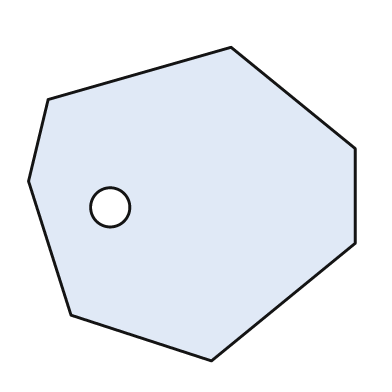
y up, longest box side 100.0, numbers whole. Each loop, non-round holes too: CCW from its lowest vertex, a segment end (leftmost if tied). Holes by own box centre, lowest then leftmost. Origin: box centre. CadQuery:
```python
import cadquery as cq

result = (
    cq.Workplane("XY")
    .moveTo(6.0, -48.0)
    .lineTo(50.0, -12.0)
    .lineTo(50.0, 17.0)
    .lineTo(12.0, 48.0)
    .lineTo(-44.0, 32.0)
    .lineTo(-50.0, 7.0)
    .lineTo(-37.0, -34.0)
    .close()
    .moveTo(-25.0, -1.0)
    .circle(6.0)
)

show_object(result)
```